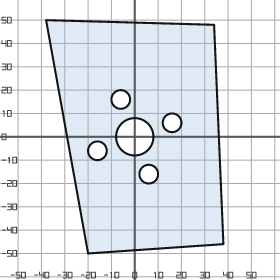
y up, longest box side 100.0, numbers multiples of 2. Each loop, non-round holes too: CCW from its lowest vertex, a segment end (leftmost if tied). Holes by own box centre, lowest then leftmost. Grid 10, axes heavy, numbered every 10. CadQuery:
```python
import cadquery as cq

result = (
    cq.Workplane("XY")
    .moveTo(-20.0, -50.0)
    .lineTo(38.0, -46.0)
    .lineTo(34.0, 48.0)
    .lineTo(-38.0, 50.0)
    .close()
    .moveTo(6.0, -16.0)
    .circle(4.0)
    .moveTo(-16.0, -6.0)
    .circle(4.0)
    .moveTo(0.0, 0.0)
    .circle(8.0)
    .moveTo(16.0, 6.0)
    .circle(4.0)
    .moveTo(-6.0, 16.0)
    .circle(4.0)
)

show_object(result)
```